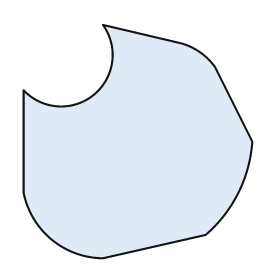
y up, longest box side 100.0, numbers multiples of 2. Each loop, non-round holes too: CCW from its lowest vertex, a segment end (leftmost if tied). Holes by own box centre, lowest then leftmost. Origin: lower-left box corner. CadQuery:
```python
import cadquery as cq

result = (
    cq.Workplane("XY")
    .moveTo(34.0, 0.0)
    .lineTo(78.0, 10.0)
    .threePointArc((92.0, 28.0), (98.0, 50.0))
    .lineTo(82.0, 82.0)
    .threePointArc((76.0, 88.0), (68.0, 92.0))
    .lineTo(34.0, 100.0)
    .threePointArc((30.0, 70.0), (0.0, 72.0))
    .lineTo(0.0, 28.0)
    .threePointArc((12.0, 8.0), (34.0, 0.0))
    .close()
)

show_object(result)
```